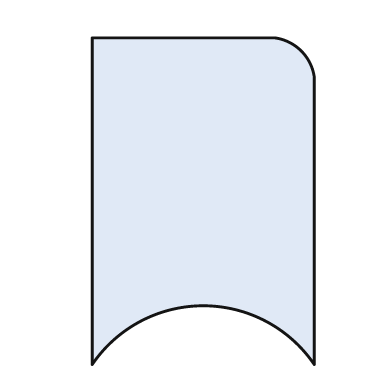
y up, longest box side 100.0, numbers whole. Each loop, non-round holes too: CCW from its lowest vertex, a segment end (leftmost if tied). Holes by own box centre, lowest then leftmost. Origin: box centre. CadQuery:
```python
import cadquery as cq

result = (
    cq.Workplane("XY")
    .moveTo(-34.0, -50.0)
    .threePointArc((0.0, -32.0), (34.0, -50.0))
    .lineTo(34.0, 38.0)
    .threePointArc((30.0, 46.0), (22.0, 50.0))
    .lineTo(-34.0, 50.0)
    .close()
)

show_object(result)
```